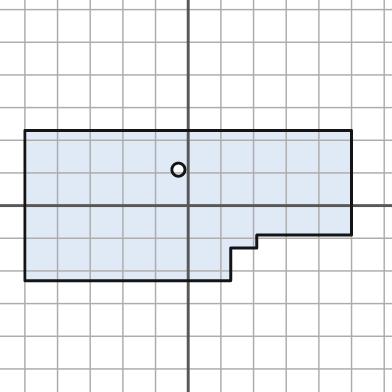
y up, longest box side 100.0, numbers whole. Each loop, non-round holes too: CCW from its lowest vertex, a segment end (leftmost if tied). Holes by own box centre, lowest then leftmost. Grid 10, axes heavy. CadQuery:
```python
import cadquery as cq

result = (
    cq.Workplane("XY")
    .moveTo(-50.0, -23.0)
    .lineTo(13.0, -23.0)
    .lineTo(13.0, -13.0)
    .lineTo(21.0, -13.0)
    .lineTo(21.0, -9.0)
    .lineTo(50.0, -9.0)
    .lineTo(50.0, 23.0)
    .lineTo(-50.0, 23.0)
    .close()
    .moveTo(-3.0, 11.0)
    .circle(2.0)
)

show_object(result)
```